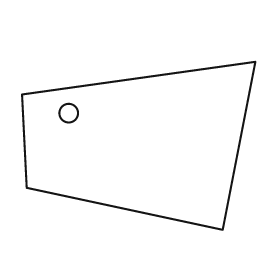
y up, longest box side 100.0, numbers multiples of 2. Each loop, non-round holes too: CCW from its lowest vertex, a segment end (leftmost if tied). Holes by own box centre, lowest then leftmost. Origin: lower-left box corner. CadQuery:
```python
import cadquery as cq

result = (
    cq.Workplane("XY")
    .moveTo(86.0, 0.0)
    .lineTo(100.0, 72.0)
    .lineTo(0.0, 58.0)
    .lineTo(2.0, 18.0)
    .close()
    .moveTo(20.0, 50.0)
    .circle(4.0)
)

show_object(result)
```